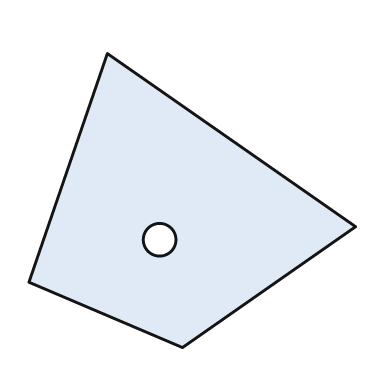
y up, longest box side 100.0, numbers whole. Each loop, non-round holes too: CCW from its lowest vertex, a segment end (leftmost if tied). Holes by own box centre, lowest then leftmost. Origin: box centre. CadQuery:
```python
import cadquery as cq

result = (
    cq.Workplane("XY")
    .moveTo(-3.0, -45.0)
    .lineTo(50.0, -8.0)
    .lineTo(-26.0, 45.0)
    .lineTo(-50.0, -25.0)
    .close()
    .moveTo(-10.0, -12.0)
    .circle(5.0)
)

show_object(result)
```